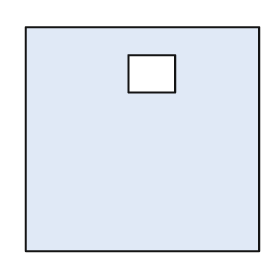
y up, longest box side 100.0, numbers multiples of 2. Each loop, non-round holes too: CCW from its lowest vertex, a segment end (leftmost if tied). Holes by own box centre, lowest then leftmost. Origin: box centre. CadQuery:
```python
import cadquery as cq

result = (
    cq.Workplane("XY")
    .moveTo(-50.0, -48.0)
    .lineTo(50.0, -48.0)
    .lineTo(50.0, 48.0)
    .lineTo(-50.0, 48.0)
    .close()
    .moveTo(-6.0, 20.0)
    .lineTo(14.0, 20.0)
    .lineTo(14.0, 36.0)
    .lineTo(-6.0, 36.0)
    .close()
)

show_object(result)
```